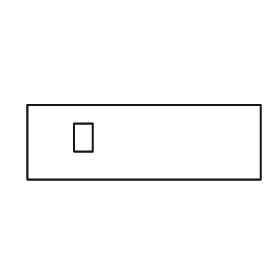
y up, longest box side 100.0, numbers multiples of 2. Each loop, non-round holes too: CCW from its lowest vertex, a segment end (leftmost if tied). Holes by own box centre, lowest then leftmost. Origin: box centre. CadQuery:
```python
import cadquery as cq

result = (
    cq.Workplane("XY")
    .moveTo(-50.0, -16.0)
    .lineTo(50.0, -16.0)
    .lineTo(50.0, 16.0)
    .lineTo(-50.0, 16.0)
    .close()
    .moveTo(-30.0, -4.0)
    .lineTo(-22.0, -4.0)
    .lineTo(-22.0, 8.0)
    .lineTo(-30.0, 8.0)
    .close()
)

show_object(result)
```